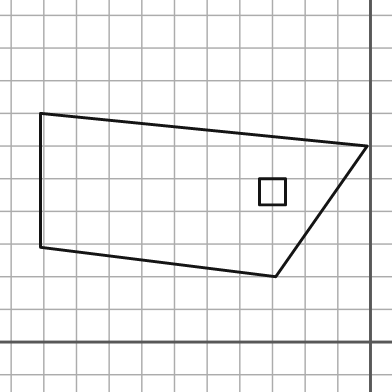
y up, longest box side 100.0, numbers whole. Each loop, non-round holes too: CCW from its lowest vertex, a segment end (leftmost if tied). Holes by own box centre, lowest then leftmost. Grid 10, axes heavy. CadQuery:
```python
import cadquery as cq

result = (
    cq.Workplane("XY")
    .moveTo(-29.0, 20.0)
    .lineTo(-1.0, 60.0)
    .lineTo(-101.0, 70.0)
    .lineTo(-101.0, 29.0)
    .close()
    .moveTo(-34.0, 42.0)
    .lineTo(-26.0, 42.0)
    .lineTo(-26.0, 50.0)
    .lineTo(-34.0, 50.0)
    .close()
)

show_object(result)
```